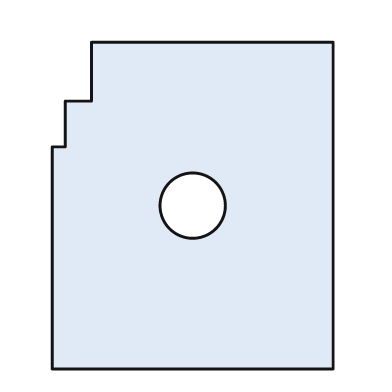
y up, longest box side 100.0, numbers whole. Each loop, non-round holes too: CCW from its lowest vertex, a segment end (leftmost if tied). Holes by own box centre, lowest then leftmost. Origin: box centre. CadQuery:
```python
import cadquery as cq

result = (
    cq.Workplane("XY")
    .moveTo(-43.0, -50.0)
    .lineTo(43.0, -50.0)
    .lineTo(43.0, 50.0)
    .lineTo(-31.0, 50.0)
    .lineTo(-31.0, 32.0)
    .lineTo(-39.0, 32.0)
    .lineTo(-39.0, 18.0)
    .lineTo(-43.0, 18.0)
    .close()
    .moveTo(0.0, 0.0)
    .circle(10.0)
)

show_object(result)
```